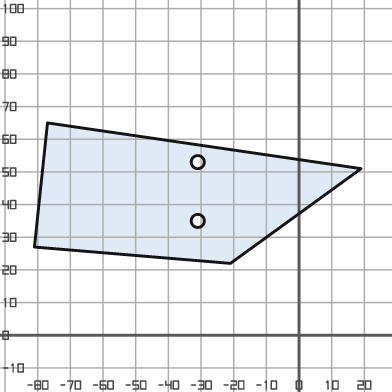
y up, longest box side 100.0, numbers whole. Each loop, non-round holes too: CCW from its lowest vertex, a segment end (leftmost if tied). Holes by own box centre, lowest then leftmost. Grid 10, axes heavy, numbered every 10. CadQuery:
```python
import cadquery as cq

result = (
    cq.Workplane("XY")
    .moveTo(-21.0, 22.0)
    .lineTo(19.0, 51.0)
    .lineTo(-77.0, 65.0)
    .lineTo(-81.0, 27.0)
    .close()
    .moveTo(-31.0, 35.0)
    .circle(2.0)
    .moveTo(-31.0, 53.0)
    .circle(2.0)
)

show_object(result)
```